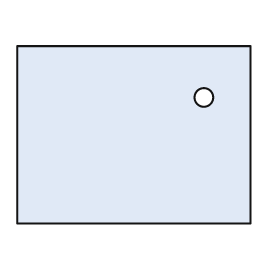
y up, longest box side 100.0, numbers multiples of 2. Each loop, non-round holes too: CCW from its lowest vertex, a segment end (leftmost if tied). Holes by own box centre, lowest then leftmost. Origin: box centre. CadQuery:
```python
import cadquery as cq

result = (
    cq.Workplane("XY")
    .moveTo(-50.0, -38.0)
    .lineTo(50.0, -38.0)
    .lineTo(50.0, 38.0)
    .lineTo(-50.0, 38.0)
    .close()
    .moveTo(30.0, 16.0)
    .circle(4.0)
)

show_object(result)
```